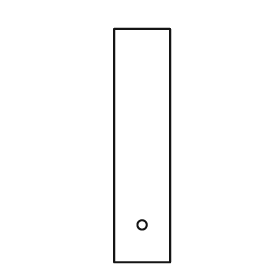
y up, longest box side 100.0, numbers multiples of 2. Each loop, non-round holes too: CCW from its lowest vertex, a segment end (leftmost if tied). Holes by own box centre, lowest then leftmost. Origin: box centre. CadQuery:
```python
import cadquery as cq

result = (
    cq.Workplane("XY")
    .moveTo(-12.0, -50.0)
    .lineTo(12.0, -50.0)
    .lineTo(12.0, 50.0)
    .lineTo(-12.0, 50.0)
    .close()
    .moveTo(0.0, -34.0)
    .circle(2.0)
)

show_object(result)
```